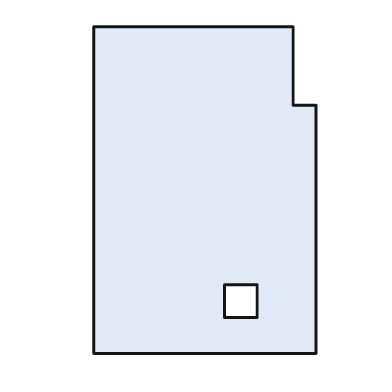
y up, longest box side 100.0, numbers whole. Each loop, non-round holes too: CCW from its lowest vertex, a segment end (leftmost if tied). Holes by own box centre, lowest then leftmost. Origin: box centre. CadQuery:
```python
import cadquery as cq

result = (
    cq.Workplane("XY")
    .moveTo(-34.0, -50.0)
    .lineTo(34.0, -50.0)
    .lineTo(34.0, 26.0)
    .lineTo(27.0, 26.0)
    .lineTo(27.0, 50.0)
    .lineTo(-34.0, 50.0)
    .close()
    .moveTo(6.0, -39.0)
    .lineTo(16.0, -39.0)
    .lineTo(16.0, -29.0)
    .lineTo(6.0, -29.0)
    .close()
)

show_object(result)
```